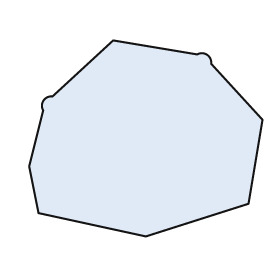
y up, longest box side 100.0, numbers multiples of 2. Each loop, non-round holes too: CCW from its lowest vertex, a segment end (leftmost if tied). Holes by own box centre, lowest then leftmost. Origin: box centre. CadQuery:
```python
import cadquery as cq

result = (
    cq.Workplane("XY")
    .moveTo(0.0, -42.0)
    .lineTo(44.0, -28.0)
    .lineTo(50.0, 8.0)
    .lineTo(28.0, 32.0)
    .threePointArc((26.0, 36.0), (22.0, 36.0))
    .lineTo(-14.0, 42.0)
    .lineTo(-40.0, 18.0)
    .threePointArc((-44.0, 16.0), (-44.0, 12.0))
    .lineTo(-50.0, -12.0)
    .lineTo(-46.0, -32.0)
    .close()
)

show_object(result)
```